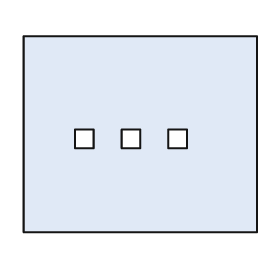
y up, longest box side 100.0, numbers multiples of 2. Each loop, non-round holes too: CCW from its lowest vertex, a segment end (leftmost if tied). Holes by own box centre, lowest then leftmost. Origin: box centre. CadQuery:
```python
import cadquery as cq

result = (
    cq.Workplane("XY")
    .moveTo(-50.0, -42.0)
    .lineTo(50.0, -42.0)
    .lineTo(50.0, 42.0)
    .lineTo(-50.0, 42.0)
    .close()
    .moveTo(-28.0, -6.0)
    .lineTo(-20.0, -6.0)
    .lineTo(-20.0, 2.0)
    .lineTo(-28.0, 2.0)
    .close()
    .moveTo(-8.0, -6.0)
    .lineTo(0.0, -6.0)
    .lineTo(0.0, 2.0)
    .lineTo(-8.0, 2.0)
    .close()
    .moveTo(12.0, -6.0)
    .lineTo(20.0, -6.0)
    .lineTo(20.0, 2.0)
    .lineTo(12.0, 2.0)
    .close()
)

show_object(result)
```